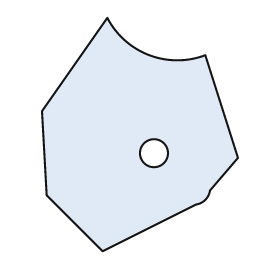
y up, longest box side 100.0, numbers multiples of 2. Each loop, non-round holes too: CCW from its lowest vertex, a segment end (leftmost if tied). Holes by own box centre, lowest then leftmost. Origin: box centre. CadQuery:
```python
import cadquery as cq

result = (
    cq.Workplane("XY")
    .moveTo(-16.0, -50.0)
    .lineTo(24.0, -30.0)
    .threePointArc((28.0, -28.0), (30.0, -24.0))
    .lineTo(42.0, -10.0)
    .lineTo(28.0, 34.0)
    .threePointArc((4.0, 34.0), (-14.0, 50.0))
    .lineTo(-42.0, 10.0)
    .lineTo(-40.0, -26.0)
    .close()
    .moveTo(6.0, -8.0)
    .circle(6.0)
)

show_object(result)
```